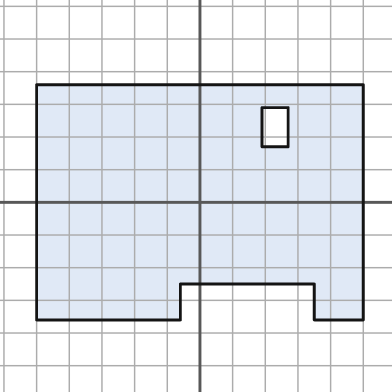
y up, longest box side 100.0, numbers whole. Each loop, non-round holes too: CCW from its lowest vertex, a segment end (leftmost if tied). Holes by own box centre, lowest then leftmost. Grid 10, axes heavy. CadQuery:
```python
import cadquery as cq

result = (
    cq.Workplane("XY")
    .moveTo(-50.0, -36.0)
    .lineTo(-6.0, -36.0)
    .lineTo(-6.0, -25.0)
    .lineTo(35.0, -25.0)
    .lineTo(35.0, -36.0)
    .lineTo(50.0, -36.0)
    .lineTo(50.0, 36.0)
    .lineTo(-50.0, 36.0)
    .close()
    .moveTo(19.0, 17.0)
    .lineTo(27.0, 17.0)
    .lineTo(27.0, 29.0)
    .lineTo(19.0, 29.0)
    .close()
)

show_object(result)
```